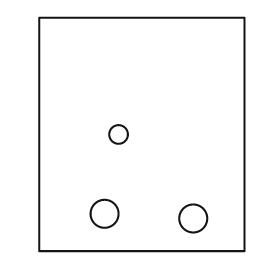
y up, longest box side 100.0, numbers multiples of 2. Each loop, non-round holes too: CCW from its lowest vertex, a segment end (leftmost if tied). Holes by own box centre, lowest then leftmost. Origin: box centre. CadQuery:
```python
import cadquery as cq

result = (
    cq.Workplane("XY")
    .moveTo(-44.0, -50.0)
    .lineTo(44.0, -50.0)
    .lineTo(44.0, 50.0)
    .lineTo(-44.0, 50.0)
    .close()
    .moveTo(22.0, -36.0)
    .circle(6.0)
    .moveTo(-16.0, -34.0)
    .circle(6.0)
    .moveTo(-10.0, 0.0)
    .circle(4.0)
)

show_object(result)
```